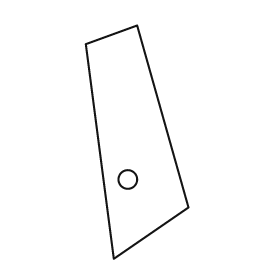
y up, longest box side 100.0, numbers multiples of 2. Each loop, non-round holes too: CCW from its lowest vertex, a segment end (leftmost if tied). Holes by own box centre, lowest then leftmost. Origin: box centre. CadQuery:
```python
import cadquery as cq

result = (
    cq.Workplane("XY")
    .moveTo(-10.0, -50.0)
    .lineTo(22.0, -28.0)
    .lineTo(0.0, 50.0)
    .lineTo(-22.0, 42.0)
    .close()
    .moveTo(-4.0, -16.0)
    .circle(4.0)
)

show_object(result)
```